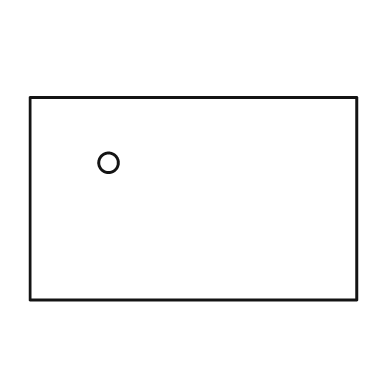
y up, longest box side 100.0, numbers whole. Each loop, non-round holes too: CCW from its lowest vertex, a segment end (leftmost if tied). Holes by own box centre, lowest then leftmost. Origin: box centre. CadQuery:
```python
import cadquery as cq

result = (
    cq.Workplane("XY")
    .moveTo(-50.0, -31.0)
    .lineTo(50.0, -31.0)
    .lineTo(50.0, 31.0)
    .lineTo(-50.0, 31.0)
    .close()
    .moveTo(-26.0, 11.0)
    .circle(3.0)
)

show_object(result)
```